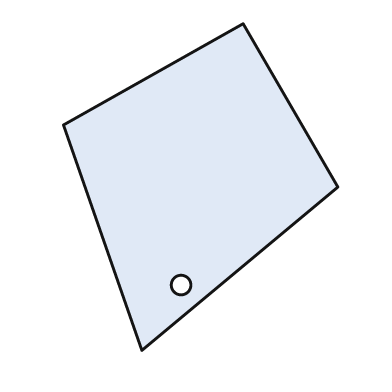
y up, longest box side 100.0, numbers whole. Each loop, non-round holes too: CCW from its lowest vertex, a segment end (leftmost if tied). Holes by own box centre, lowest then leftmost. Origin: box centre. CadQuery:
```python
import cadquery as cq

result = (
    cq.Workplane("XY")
    .moveTo(-18.0, -50.0)
    .lineTo(42.0, 0.0)
    .lineTo(13.0, 50.0)
    .lineTo(-42.0, 19.0)
    .close()
    .moveTo(-6.0, -30.0)
    .circle(3.0)
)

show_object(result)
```